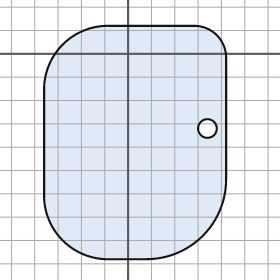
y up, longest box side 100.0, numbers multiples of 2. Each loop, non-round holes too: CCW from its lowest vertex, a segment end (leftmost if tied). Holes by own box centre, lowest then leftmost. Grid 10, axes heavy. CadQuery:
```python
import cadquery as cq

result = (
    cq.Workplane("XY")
    .moveTo(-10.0, -88.0)
    .lineTo(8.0, -88.0)
    .threePointArc((32.0, -78.0), (42.0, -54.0))
    .lineTo(42.0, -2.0)
    .threePointArc((38.0, 8.0), (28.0, 12.0))
    .lineTo(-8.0, 12.0)
    .threePointArc((-28.0, 4.0), (-36.0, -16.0))
    .lineTo(-36.0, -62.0)
    .threePointArc((-28.0, -80.0), (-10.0, -88.0))
    .close()
    .moveTo(34.0, -32.0)
    .circle(4.0)
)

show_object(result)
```